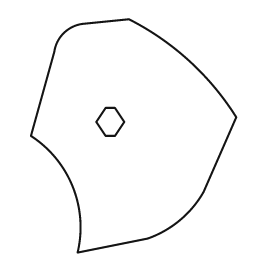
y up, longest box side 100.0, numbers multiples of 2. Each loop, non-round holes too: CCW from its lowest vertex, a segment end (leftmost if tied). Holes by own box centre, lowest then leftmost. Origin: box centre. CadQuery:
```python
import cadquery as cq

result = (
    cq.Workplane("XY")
    .moveTo(-24.0, -50.0)
    .lineTo(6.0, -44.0)
    .threePointArc((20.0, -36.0), (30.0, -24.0))
    .lineTo(44.0, 8.0)
    .threePointArc((24.0, 32.0), (-2.0, 50.0))
    .lineTo(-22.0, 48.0)
    .threePointArc((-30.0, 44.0), (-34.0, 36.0))
    .lineTo(-44.0, 0.0)
    .threePointArc((-26.0, -22.0), (-24.0, -50.0))
    .close()
    .moveTo(-12.0, 0.0)
    .lineTo(-8.0, 0.0)
    .lineTo(-4.0, 6.0)
    .lineTo(-8.0, 12.0)
    .lineTo(-12.0, 12.0)
    .lineTo(-16.0, 6.0)
    .close()
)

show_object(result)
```